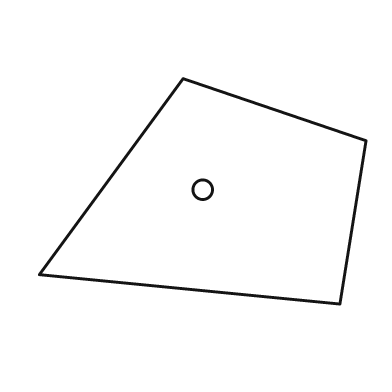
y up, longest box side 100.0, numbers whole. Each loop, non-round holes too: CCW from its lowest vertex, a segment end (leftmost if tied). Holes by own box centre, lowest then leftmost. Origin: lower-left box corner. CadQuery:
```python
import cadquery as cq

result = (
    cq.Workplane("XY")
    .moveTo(92.0, 0.0)
    .lineTo(100.0, 50.0)
    .lineTo(44.0, 69.0)
    .lineTo(0.0, 9.0)
    .close()
    .moveTo(50.0, 35.0)
    .circle(3.0)
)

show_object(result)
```